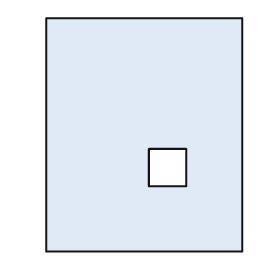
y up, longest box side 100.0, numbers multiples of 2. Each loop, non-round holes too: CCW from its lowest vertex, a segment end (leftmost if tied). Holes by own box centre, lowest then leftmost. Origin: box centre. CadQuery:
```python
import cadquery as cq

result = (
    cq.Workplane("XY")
    .moveTo(-42.0, -50.0)
    .lineTo(42.0, -50.0)
    .lineTo(42.0, 50.0)
    .lineTo(-42.0, 50.0)
    .close()
    .moveTo(2.0, -22.0)
    .lineTo(18.0, -22.0)
    .lineTo(18.0, -6.0)
    .lineTo(2.0, -6.0)
    .close()
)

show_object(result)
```